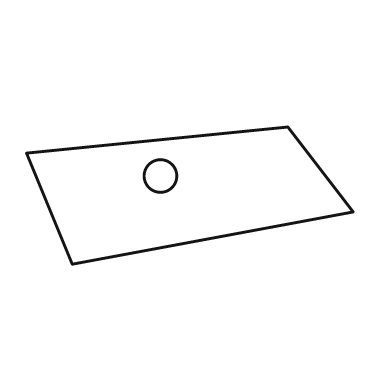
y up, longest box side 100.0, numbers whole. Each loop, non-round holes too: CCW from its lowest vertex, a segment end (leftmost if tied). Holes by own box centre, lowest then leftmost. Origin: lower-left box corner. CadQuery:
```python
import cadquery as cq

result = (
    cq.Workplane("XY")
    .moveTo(14.0, 0.0)
    .lineTo(100.0, 16.0)
    .lineTo(80.0, 42.0)
    .lineTo(0.0, 34.0)
    .close()
    .moveTo(41.0, 27.0)
    .circle(5.0)
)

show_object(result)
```